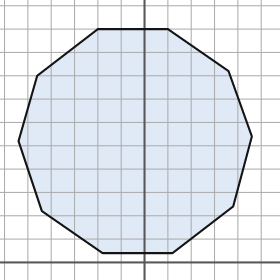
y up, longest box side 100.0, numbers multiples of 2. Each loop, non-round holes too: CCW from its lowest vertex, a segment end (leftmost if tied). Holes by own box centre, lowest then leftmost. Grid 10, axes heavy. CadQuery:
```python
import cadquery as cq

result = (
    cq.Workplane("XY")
    .moveTo(-18.0, 4.0)
    .lineTo(12.0, 4.0)
    .lineTo(38.0, 24.0)
    .lineTo(46.0, 54.0)
    .lineTo(36.0, 82.0)
    .lineTo(10.0, 100.0)
    .lineTo(-20.0, 100.0)
    .lineTo(-46.0, 80.0)
    .lineTo(-54.0, 52.0)
    .lineTo(-44.0, 22.0)
    .close()
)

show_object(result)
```